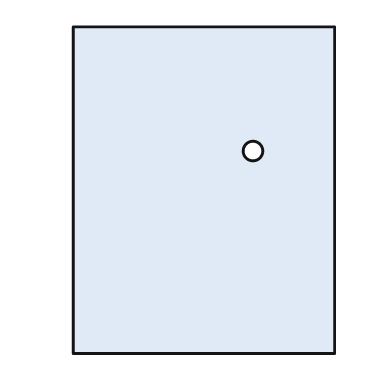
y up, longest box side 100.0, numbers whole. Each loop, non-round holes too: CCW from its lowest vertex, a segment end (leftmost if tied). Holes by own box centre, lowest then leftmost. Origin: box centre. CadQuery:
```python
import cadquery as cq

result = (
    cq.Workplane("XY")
    .moveTo(-40.0, -50.0)
    .lineTo(40.0, -50.0)
    .lineTo(40.0, 50.0)
    .lineTo(-40.0, 50.0)
    .close()
    .moveTo(15.0, 12.0)
    .circle(3.0)
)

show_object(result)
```